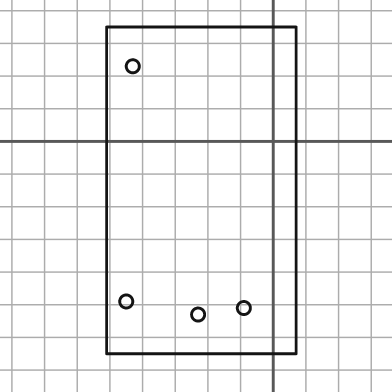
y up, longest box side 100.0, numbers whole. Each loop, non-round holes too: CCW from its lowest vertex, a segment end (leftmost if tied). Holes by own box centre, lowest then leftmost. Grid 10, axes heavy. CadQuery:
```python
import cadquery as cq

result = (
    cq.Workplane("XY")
    .moveTo(-51.0, -65.0)
    .lineTo(7.0, -65.0)
    .lineTo(7.0, 35.0)
    .lineTo(-51.0, 35.0)
    .close()
    .moveTo(-23.0, -53.0)
    .circle(2.0)
    .moveTo(-9.0, -51.0)
    .circle(2.0)
    .moveTo(-45.0, -49.0)
    .circle(2.0)
    .moveTo(-43.0, 23.0)
    .circle(2.0)
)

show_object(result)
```